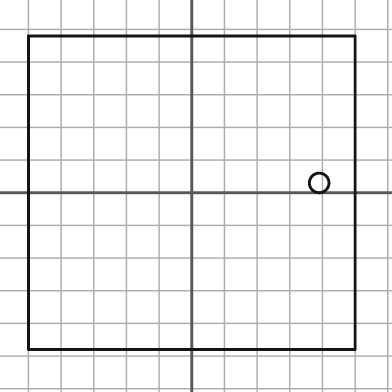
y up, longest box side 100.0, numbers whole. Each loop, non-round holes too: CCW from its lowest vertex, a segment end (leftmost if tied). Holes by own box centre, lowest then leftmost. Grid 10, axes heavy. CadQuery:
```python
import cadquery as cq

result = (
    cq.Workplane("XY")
    .moveTo(-50.0, -48.0)
    .lineTo(50.0, -48.0)
    .lineTo(50.0, 48.0)
    .lineTo(-50.0, 48.0)
    .close()
    .moveTo(39.0, 3.0)
    .circle(3.0)
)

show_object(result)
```